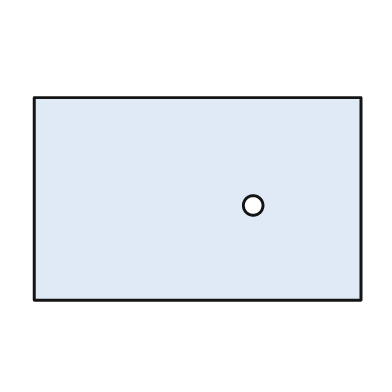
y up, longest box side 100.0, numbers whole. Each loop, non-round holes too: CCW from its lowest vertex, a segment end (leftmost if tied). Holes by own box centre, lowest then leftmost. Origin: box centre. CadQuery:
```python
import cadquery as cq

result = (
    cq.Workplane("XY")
    .moveTo(-50.0, -31.0)
    .lineTo(50.0, -31.0)
    .lineTo(50.0, 31.0)
    .lineTo(-50.0, 31.0)
    .close()
    .moveTo(17.0, -2.0)
    .circle(3.0)
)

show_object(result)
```